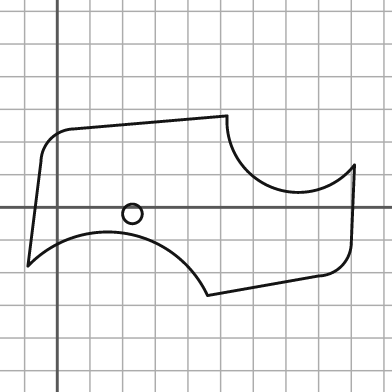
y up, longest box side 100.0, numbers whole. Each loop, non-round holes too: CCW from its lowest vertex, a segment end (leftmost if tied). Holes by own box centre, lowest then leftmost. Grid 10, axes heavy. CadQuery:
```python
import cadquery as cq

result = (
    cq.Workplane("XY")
    .moveTo(46.0, -27.0)
    .lineTo(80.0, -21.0)
    .threePointArc((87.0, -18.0), (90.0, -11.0))
    .lineTo(91.0, 13.0)
    .threePointArc((66.0, 6.0), (52.0, 28.0))
    .lineTo(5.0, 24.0)
    .threePointArc((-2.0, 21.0), (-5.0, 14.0))
    .lineTo(-9.0, -18.0)
    .threePointArc((21.0, -8.0), (46.0, -27.0))
    .close()
    .moveTo(23.0, -2.0)
    .circle(3.0)
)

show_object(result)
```